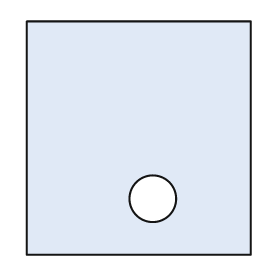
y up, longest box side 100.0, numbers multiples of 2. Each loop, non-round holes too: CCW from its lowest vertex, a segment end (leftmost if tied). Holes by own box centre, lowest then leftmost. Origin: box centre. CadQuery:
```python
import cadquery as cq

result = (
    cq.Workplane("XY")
    .moveTo(-48.0, -50.0)
    .lineTo(48.0, -50.0)
    .lineTo(48.0, 50.0)
    .lineTo(-48.0, 50.0)
    .close()
    .moveTo(6.0, -26.0)
    .circle(10.0)
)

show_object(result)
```